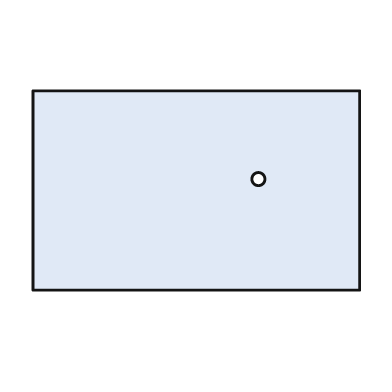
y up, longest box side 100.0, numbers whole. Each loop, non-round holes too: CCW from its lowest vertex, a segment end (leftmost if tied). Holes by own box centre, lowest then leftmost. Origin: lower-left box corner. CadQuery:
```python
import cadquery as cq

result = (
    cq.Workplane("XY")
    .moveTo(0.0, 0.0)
    .lineTo(100.0, 0.0)
    .lineTo(100.0, 61.0)
    .lineTo(0.0, 61.0)
    .close()
    .moveTo(69.0, 34.0)
    .circle(2.0)
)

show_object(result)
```